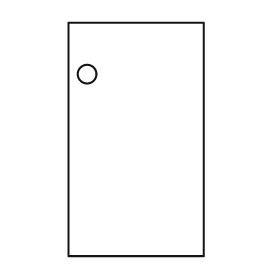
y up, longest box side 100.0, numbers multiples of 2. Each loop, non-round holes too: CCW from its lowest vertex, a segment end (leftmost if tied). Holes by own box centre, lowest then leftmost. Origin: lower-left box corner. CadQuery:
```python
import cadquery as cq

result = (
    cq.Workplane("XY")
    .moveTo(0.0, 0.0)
    .lineTo(58.0, 0.0)
    .lineTo(58.0, 100.0)
    .lineTo(0.0, 100.0)
    .close()
    .moveTo(8.0, 78.0)
    .circle(4.0)
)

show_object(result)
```